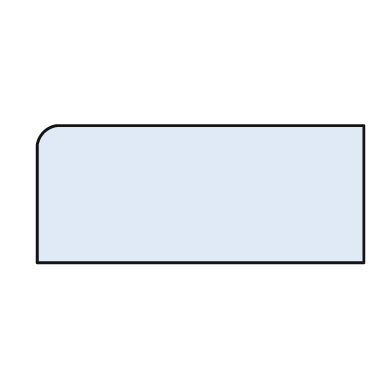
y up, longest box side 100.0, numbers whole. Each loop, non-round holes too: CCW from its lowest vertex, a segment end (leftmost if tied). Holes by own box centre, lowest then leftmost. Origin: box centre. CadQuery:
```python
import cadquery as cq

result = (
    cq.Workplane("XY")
    .moveTo(-50.0, -21.0)
    .lineTo(50.0, -21.0)
    .lineTo(50.0, 21.0)
    .lineTo(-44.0, 21.0)
    .threePointArc((-48.0, 19.0), (-50.0, 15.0))
    .close()
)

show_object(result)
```